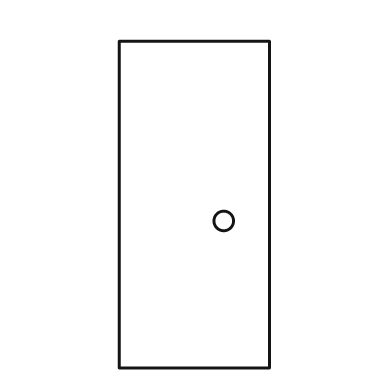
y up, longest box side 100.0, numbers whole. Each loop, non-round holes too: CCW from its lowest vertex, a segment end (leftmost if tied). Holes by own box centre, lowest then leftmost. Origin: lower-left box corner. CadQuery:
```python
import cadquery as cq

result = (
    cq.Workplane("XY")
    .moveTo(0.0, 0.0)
    .lineTo(46.0, 0.0)
    .lineTo(46.0, 100.0)
    .lineTo(0.0, 100.0)
    .close()
    .moveTo(32.0, 45.0)
    .circle(3.0)
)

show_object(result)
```